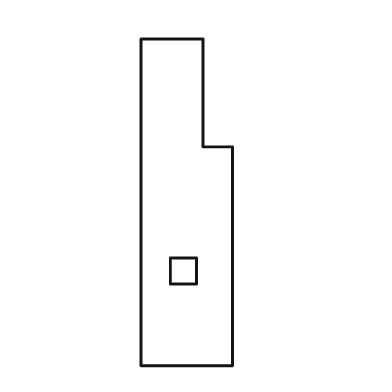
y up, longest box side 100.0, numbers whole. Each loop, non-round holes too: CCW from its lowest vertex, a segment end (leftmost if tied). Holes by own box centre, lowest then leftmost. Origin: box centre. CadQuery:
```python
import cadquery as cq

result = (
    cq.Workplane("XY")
    .moveTo(-14.0, -50.0)
    .lineTo(14.0, -50.0)
    .lineTo(14.0, 17.0)
    .lineTo(5.0, 17.0)
    .lineTo(5.0, 50.0)
    .lineTo(-14.0, 50.0)
    .close()
    .moveTo(-5.0, -25.0)
    .lineTo(3.0, -25.0)
    .lineTo(3.0, -17.0)
    .lineTo(-5.0, -17.0)
    .close()
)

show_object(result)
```